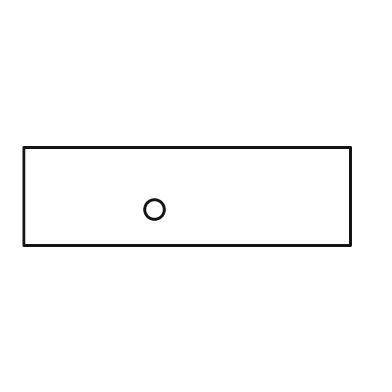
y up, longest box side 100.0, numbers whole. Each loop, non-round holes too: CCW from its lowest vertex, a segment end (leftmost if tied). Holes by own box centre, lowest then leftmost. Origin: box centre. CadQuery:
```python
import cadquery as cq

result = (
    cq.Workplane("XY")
    .moveTo(-50.0, -15.0)
    .lineTo(50.0, -15.0)
    .lineTo(50.0, 15.0)
    .lineTo(-50.0, 15.0)
    .close()
    .moveTo(-10.0, -4.0)
    .circle(3.0)
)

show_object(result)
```